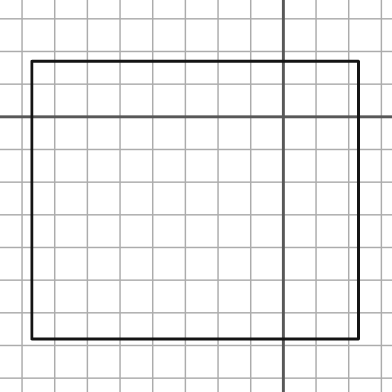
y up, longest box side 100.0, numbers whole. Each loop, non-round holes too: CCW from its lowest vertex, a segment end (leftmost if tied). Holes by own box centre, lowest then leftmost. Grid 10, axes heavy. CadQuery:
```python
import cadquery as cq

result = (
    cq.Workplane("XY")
    .moveTo(-77.0, -68.0)
    .lineTo(23.0, -68.0)
    .lineTo(23.0, 17.0)
    .lineTo(-77.0, 17.0)
    .close()
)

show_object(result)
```